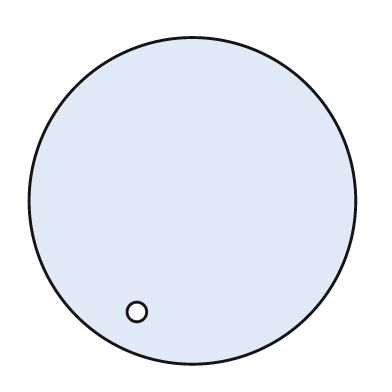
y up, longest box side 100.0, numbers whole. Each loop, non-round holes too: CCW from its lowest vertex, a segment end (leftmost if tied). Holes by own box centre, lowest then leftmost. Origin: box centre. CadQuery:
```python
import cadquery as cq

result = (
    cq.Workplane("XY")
    .moveTo(0.0, 0.0)
    .circle(50.0)
    .moveTo(-17.0, -34.0)
    .circle(3.0)
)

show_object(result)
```